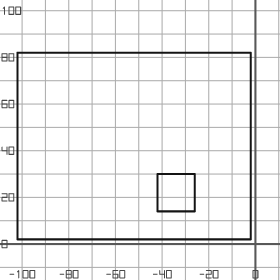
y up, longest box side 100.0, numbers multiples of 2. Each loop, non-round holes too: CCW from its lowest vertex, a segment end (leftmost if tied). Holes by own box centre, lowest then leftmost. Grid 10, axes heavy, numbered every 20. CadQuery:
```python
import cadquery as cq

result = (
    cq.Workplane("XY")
    .moveTo(-102.0, 2.0)
    .lineTo(-2.0, 2.0)
    .lineTo(-2.0, 82.0)
    .lineTo(-102.0, 82.0)
    .close()
    .moveTo(-42.0, 14.0)
    .lineTo(-26.0, 14.0)
    .lineTo(-26.0, 30.0)
    .lineTo(-42.0, 30.0)
    .close()
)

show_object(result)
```